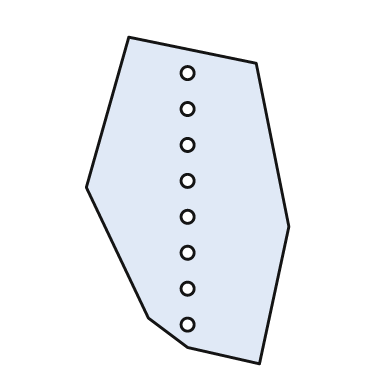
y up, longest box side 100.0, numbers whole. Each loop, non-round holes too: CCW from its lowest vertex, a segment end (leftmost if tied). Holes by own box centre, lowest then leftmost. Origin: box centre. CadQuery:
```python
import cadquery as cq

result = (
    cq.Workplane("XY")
    .moveTo(22.0, -50.0)
    .lineTo(31.0, -8.0)
    .lineTo(21.0, 42.0)
    .lineTo(-18.0, 50.0)
    .lineTo(-31.0, 4.0)
    .lineTo(-12.0, -36.0)
    .lineTo(0.0, -45.0)
    .close()
    .moveTo(0.0, -38.0)
    .circle(2.0)
    .moveTo(0.0, -27.0)
    .circle(2.0)
    .moveTo(0.0, -16.0)
    .circle(2.0)
    .moveTo(0.0, -5.0)
    .circle(2.0)
    .moveTo(0.0, 6.0)
    .circle(2.0)
    .moveTo(0.0, 17.0)
    .circle(2.0)
    .moveTo(0.0, 28.0)
    .circle(2.0)
    .moveTo(0.0, 39.0)
    .circle(2.0)
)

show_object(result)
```